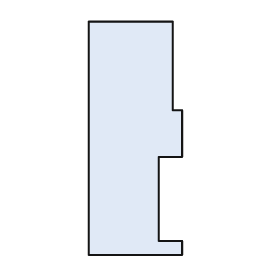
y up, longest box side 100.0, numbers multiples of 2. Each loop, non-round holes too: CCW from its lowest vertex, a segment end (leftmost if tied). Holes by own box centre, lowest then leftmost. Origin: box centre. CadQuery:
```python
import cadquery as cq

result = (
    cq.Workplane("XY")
    .moveTo(-20.0, -50.0)
    .lineTo(20.0, -50.0)
    .lineTo(20.0, -44.0)
    .lineTo(10.0, -44.0)
    .lineTo(10.0, -8.0)
    .lineTo(20.0, -8.0)
    .lineTo(20.0, 12.0)
    .lineTo(16.0, 12.0)
    .lineTo(16.0, 50.0)
    .lineTo(-20.0, 50.0)
    .close()
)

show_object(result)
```